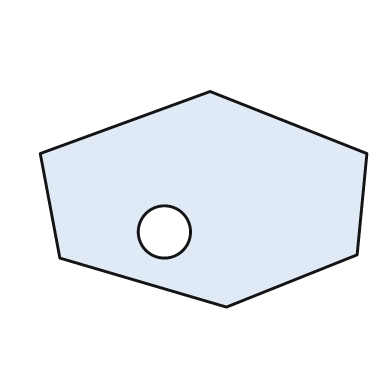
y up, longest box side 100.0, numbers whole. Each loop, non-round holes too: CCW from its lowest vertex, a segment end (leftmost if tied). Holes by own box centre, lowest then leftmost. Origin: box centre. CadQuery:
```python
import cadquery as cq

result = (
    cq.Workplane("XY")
    .moveTo(7.0, -33.0)
    .lineTo(47.0, -17.0)
    .lineTo(50.0, 14.0)
    .lineTo(2.0, 33.0)
    .lineTo(-50.0, 14.0)
    .lineTo(-44.0, -18.0)
    .close()
    .moveTo(-12.0, -10.0)
    .circle(8.0)
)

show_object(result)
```